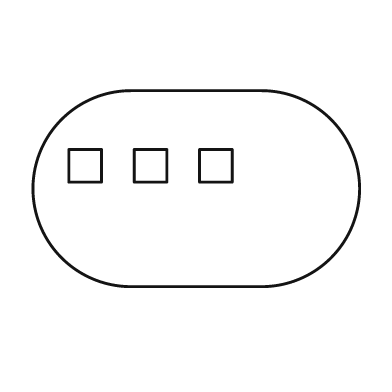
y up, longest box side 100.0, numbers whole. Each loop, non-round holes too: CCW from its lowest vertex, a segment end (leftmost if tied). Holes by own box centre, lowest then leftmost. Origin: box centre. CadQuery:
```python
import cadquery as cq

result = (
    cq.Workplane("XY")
    .moveTo(-20.0, -30.0)
    .lineTo(20.0, -30.0)
    .threePointArc((50.0, 0.0), (20.0, 30.0))
    .lineTo(-20.0, 30.0)
    .threePointArc((-50.0, 0.0), (-20.0, -30.0))
    .close()
    .moveTo(-39.0, 2.0)
    .lineTo(-29.0, 2.0)
    .lineTo(-29.0, 12.0)
    .lineTo(-39.0, 12.0)
    .close()
    .moveTo(-19.0, 2.0)
    .lineTo(-9.0, 2.0)
    .lineTo(-9.0, 12.0)
    .lineTo(-19.0, 12.0)
    .close()
    .moveTo(1.0, 2.0)
    .lineTo(11.0, 2.0)
    .lineTo(11.0, 12.0)
    .lineTo(1.0, 12.0)
    .close()
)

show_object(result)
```